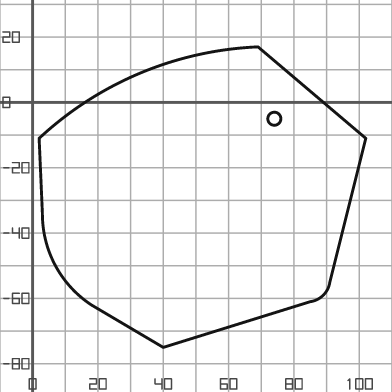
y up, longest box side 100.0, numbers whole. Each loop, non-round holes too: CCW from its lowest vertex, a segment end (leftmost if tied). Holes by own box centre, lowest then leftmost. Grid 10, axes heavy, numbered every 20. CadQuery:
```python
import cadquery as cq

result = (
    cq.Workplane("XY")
    .moveTo(40.0, -75.0)
    .lineTo(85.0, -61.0)
    .threePointArc((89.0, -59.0), (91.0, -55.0))
    .lineTo(102.0, -11.0)
    .lineTo(69.0, 17.0)
    .threePointArc((33.0, 9.0), (2.0, -11.0))
    .lineTo(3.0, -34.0)
    .threePointArc((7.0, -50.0), (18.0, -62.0))
    .close()
    .moveTo(74.0, -5.0)
    .circle(2.0)
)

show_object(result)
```